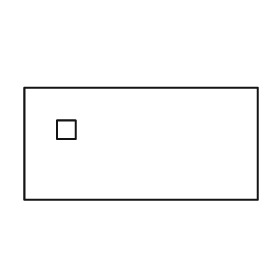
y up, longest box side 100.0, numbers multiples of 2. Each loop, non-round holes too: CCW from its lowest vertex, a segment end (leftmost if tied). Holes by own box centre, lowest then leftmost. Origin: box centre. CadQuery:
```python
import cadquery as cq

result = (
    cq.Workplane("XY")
    .moveTo(-50.0, -24.0)
    .lineTo(50.0, -24.0)
    .lineTo(50.0, 24.0)
    .lineTo(-50.0, 24.0)
    .close()
    .moveTo(-36.0, 2.0)
    .lineTo(-28.0, 2.0)
    .lineTo(-28.0, 10.0)
    .lineTo(-36.0, 10.0)
    .close()
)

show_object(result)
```